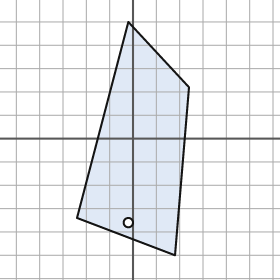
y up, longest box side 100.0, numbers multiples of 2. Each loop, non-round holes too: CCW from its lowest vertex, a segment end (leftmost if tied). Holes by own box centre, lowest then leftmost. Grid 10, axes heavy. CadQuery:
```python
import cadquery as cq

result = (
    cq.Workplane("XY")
    .moveTo(18.0, -50.0)
    .lineTo(24.0, 22.0)
    .lineTo(-2.0, 50.0)
    .lineTo(-24.0, -34.0)
    .close()
    .moveTo(-2.0, -36.0)
    .circle(2.0)
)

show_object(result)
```